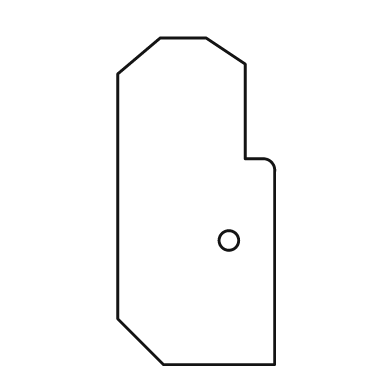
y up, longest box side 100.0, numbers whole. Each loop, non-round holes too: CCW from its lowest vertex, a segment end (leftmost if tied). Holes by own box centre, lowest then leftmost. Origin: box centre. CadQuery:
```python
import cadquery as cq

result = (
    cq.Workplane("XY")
    .moveTo(-10.0, -50.0)
    .lineTo(24.0, -50.0)
    .lineTo(24.0, 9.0)
    .threePointArc((23.0, 12.0), (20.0, 13.0))
    .lineTo(15.0, 13.0)
    .lineTo(15.0, 42.0)
    .lineTo(3.0, 50.0)
    .lineTo(-11.0, 50.0)
    .lineTo(-24.0, 39.0)
    .lineTo(-24.0, -36.0)
    .close()
    .moveTo(10.0, -12.0)
    .circle(3.0)
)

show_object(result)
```